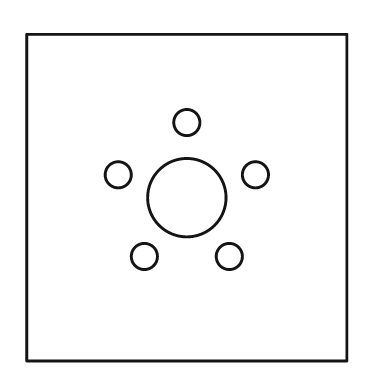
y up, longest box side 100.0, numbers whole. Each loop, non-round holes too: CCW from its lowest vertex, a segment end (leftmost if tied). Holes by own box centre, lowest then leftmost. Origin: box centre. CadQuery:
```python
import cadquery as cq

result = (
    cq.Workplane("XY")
    .moveTo(-49.0, -50.0)
    .lineTo(49.0, -50.0)
    .lineTo(49.0, 50.0)
    .lineTo(-49.0, 50.0)
    .close()
    .moveTo(-13.0, -18.0)
    .circle(4.0)
    .moveTo(13.0, -18.0)
    .circle(4.0)
    .moveTo(0.0, 0.0)
    .circle(12.0)
    .moveTo(-21.0, 7.0)
    .circle(4.0)
    .moveTo(21.0, 7.0)
    .circle(4.0)
    .moveTo(0.0, 23.0)
    .circle(4.0)
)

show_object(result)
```